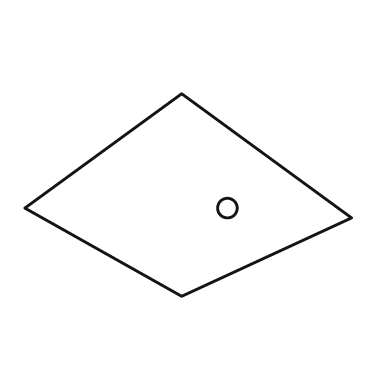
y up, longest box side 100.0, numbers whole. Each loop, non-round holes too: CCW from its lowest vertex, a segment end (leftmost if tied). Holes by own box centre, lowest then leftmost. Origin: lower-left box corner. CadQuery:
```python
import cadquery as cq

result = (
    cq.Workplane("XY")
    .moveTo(48.0, 0.0)
    .lineTo(100.0, 24.0)
    .lineTo(48.0, 62.0)
    .lineTo(0.0, 27.0)
    .close()
    .moveTo(62.0, 27.0)
    .circle(3.0)
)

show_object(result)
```